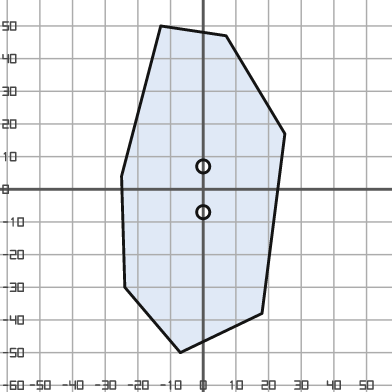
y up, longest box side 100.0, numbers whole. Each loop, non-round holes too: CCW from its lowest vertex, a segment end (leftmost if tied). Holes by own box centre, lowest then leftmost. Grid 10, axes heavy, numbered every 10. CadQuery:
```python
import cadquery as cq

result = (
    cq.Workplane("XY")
    .moveTo(-7.0, -50.0)
    .lineTo(18.0, -38.0)
    .lineTo(25.0, 17.0)
    .lineTo(7.0, 47.0)
    .lineTo(-13.0, 50.0)
    .lineTo(-25.0, 4.0)
    .lineTo(-24.0, -30.0)
    .close()
    .moveTo(0.0, -7.0)
    .circle(2.0)
    .moveTo(0.0, 7.0)
    .circle(2.0)
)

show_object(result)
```